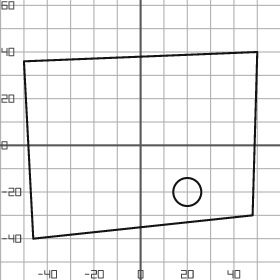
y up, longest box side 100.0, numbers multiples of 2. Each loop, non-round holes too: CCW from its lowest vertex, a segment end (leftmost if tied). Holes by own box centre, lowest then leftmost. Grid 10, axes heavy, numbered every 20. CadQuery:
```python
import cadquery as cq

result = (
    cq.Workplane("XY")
    .moveTo(-46.0, -40.0)
    .lineTo(48.0, -30.0)
    .lineTo(50.0, 40.0)
    .lineTo(-50.0, 36.0)
    .close()
    .moveTo(20.0, -20.0)
    .circle(6.0)
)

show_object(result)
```